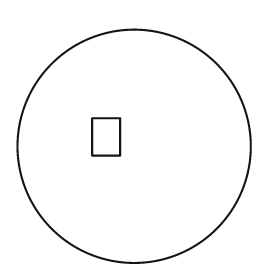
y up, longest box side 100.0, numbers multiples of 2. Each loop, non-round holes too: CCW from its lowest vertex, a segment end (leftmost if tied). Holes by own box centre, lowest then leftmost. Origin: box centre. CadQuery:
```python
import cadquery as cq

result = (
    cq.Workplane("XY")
    .moveTo(0.0, 0.0)
    .circle(50.0)
    .moveTo(-18.0, -4.0)
    .lineTo(-6.0, -4.0)
    .lineTo(-6.0, 12.0)
    .lineTo(-18.0, 12.0)
    .close()
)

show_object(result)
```